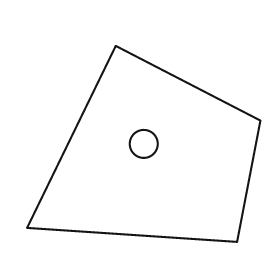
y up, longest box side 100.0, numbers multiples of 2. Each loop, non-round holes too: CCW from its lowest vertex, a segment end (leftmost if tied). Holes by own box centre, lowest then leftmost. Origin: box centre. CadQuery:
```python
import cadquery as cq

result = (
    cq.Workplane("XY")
    .moveTo(40.0, -42.0)
    .lineTo(50.0, 10.0)
    .lineTo(-12.0, 42.0)
    .lineTo(-50.0, -36.0)
    .close()
    .moveTo(0.0, 0.0)
    .circle(6.0)
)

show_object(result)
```